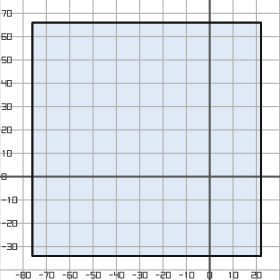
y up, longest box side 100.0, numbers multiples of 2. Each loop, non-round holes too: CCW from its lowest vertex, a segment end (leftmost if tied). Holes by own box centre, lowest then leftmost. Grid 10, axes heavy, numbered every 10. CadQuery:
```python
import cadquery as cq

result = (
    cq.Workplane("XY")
    .moveTo(-76.0, -34.0)
    .lineTo(22.0, -34.0)
    .lineTo(22.0, 66.0)
    .lineTo(-76.0, 66.0)
    .close()
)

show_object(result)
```